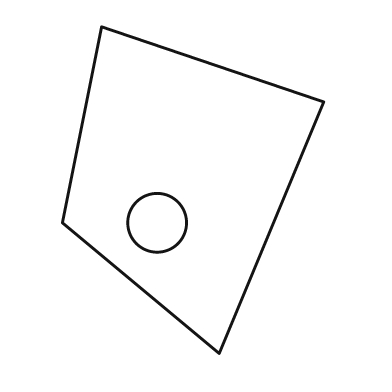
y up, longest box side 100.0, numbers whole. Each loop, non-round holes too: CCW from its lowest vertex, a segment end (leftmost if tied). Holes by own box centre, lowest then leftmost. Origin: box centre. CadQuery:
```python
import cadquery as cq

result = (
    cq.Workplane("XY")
    .moveTo(8.0, -50.0)
    .lineTo(40.0, 27.0)
    .lineTo(-28.0, 50.0)
    .lineTo(-40.0, -10.0)
    .close()
    .moveTo(-11.0, -10.0)
    .circle(9.0)
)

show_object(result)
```